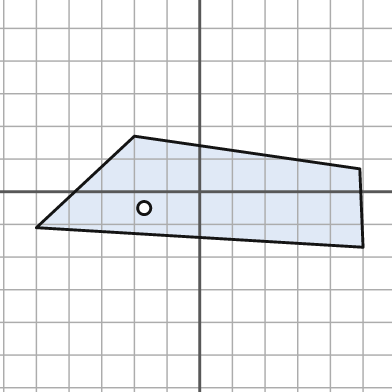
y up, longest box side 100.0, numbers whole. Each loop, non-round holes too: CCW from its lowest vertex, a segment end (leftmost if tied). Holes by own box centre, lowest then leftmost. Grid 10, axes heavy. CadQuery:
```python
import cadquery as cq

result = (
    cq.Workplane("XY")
    .moveTo(50.0, -17.0)
    .lineTo(49.0, 7.0)
    .lineTo(-20.0, 17.0)
    .lineTo(-50.0, -11.0)
    .close()
    .moveTo(-17.0, -5.0)
    .circle(2.0)
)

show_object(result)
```